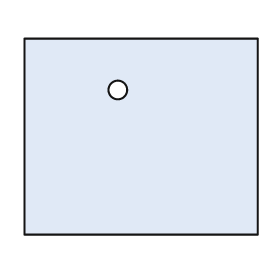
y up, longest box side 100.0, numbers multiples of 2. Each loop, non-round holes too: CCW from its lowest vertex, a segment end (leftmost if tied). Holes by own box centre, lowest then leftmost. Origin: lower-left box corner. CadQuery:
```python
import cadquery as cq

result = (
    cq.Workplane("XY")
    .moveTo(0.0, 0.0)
    .lineTo(100.0, 0.0)
    .lineTo(100.0, 84.0)
    .lineTo(0.0, 84.0)
    .close()
    .moveTo(40.0, 62.0)
    .circle(4.0)
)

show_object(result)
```